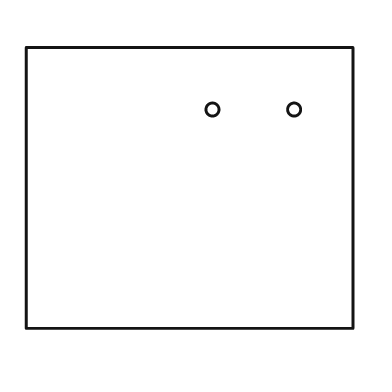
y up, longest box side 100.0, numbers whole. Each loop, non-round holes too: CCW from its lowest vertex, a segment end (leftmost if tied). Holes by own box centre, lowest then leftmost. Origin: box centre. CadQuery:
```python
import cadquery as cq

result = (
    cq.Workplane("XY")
    .moveTo(-50.0, -43.0)
    .lineTo(50.0, -43.0)
    .lineTo(50.0, 43.0)
    .lineTo(-50.0, 43.0)
    .close()
    .moveTo(7.0, 24.0)
    .circle(2.0)
    .moveTo(32.0, 24.0)
    .circle(2.0)
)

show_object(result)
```